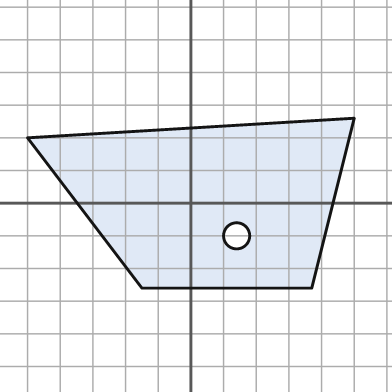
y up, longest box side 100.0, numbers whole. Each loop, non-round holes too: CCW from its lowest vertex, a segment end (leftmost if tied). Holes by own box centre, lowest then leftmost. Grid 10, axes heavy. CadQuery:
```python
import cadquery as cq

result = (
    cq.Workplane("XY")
    .moveTo(-15.0, -26.0)
    .lineTo(37.0, -26.0)
    .lineTo(50.0, 26.0)
    .lineTo(-50.0, 20.0)
    .close()
    .moveTo(14.0, -10.0)
    .circle(4.0)
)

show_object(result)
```